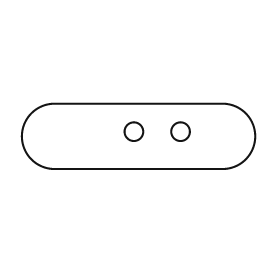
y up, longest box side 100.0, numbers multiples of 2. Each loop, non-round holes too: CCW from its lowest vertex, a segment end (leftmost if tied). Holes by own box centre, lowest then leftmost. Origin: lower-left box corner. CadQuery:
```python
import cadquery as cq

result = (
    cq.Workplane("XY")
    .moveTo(14.0, 0.0)
    .lineTo(86.0, 0.0)
    .threePointArc((100.0, 14.0), (86.0, 28.0))
    .lineTo(14.0, 28.0)
    .threePointArc((0.0, 14.0), (14.0, 0.0))
    .close()
    .moveTo(48.0, 16.0)
    .circle(4.0)
    .moveTo(68.0, 16.0)
    .circle(4.0)
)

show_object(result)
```